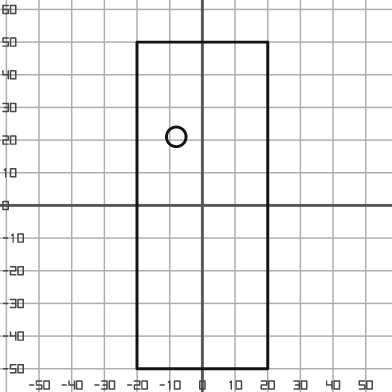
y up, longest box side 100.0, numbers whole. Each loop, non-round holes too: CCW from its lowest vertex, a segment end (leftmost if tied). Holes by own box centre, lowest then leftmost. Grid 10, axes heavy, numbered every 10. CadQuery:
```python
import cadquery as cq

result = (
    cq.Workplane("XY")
    .moveTo(-20.0, -50.0)
    .lineTo(20.0, -50.0)
    .lineTo(20.0, 50.0)
    .lineTo(-20.0, 50.0)
    .close()
    .moveTo(-8.0, 21.0)
    .circle(3.0)
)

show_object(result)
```